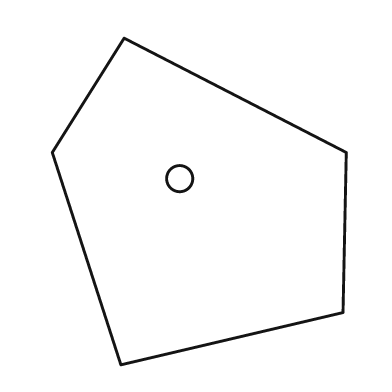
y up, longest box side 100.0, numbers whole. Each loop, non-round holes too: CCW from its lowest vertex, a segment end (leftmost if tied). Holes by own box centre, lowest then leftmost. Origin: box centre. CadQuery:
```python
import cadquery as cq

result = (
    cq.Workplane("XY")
    .moveTo(-24.0, -50.0)
    .lineTo(44.0, -34.0)
    .lineTo(45.0, 15.0)
    .lineTo(-23.0, 50.0)
    .lineTo(-45.0, 15.0)
    .close()
    .moveTo(-6.0, 7.0)
    .circle(4.0)
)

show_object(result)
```